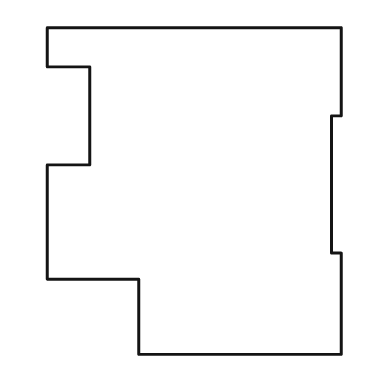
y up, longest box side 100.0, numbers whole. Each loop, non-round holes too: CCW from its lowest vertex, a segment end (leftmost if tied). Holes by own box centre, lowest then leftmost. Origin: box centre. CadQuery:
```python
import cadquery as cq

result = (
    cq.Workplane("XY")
    .moveTo(-17.0, -50.0)
    .lineTo(45.0, -50.0)
    .lineTo(45.0, -19.0)
    .lineTo(42.0, -19.0)
    .lineTo(42.0, 23.0)
    .lineTo(45.0, 23.0)
    .lineTo(45.0, 50.0)
    .lineTo(-45.0, 50.0)
    .lineTo(-45.0, 38.0)
    .lineTo(-32.0, 38.0)
    .lineTo(-32.0, 8.0)
    .lineTo(-45.0, 8.0)
    .lineTo(-45.0, -27.0)
    .lineTo(-17.0, -27.0)
    .close()
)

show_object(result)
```